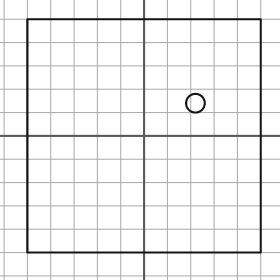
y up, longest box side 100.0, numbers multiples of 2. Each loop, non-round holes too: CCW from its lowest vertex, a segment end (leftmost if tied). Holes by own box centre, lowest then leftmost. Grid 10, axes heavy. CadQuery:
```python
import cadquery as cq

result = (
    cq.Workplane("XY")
    .moveTo(-50.0, -50.0)
    .lineTo(50.0, -50.0)
    .lineTo(50.0, 50.0)
    .lineTo(-50.0, 50.0)
    .close()
    .moveTo(22.0, 14.0)
    .circle(4.0)
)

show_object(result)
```